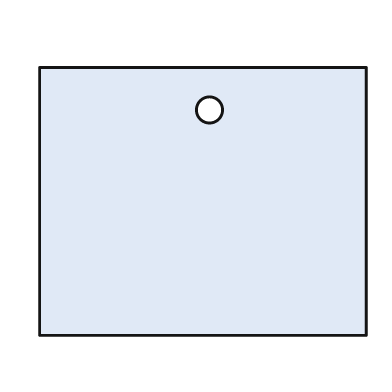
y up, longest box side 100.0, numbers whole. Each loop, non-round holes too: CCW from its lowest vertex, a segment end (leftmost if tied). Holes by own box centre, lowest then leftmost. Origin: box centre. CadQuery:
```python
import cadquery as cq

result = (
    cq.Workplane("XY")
    .moveTo(-50.0, -41.0)
    .lineTo(50.0, -41.0)
    .lineTo(50.0, 41.0)
    .lineTo(-50.0, 41.0)
    .close()
    .moveTo(2.0, 28.0)
    .circle(4.0)
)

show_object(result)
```